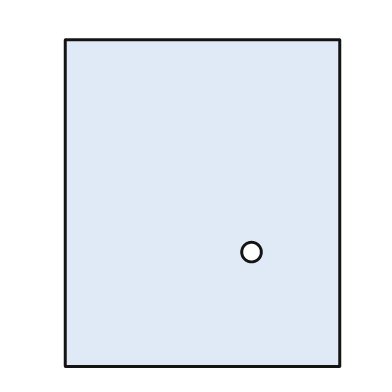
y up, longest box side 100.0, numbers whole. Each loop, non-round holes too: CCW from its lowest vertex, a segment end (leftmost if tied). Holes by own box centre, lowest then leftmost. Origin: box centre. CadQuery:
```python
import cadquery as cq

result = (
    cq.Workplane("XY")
    .moveTo(-42.0, -50.0)
    .lineTo(42.0, -50.0)
    .lineTo(42.0, 50.0)
    .lineTo(-42.0, 50.0)
    .close()
    .moveTo(15.0, -15.0)
    .circle(3.0)
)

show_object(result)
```